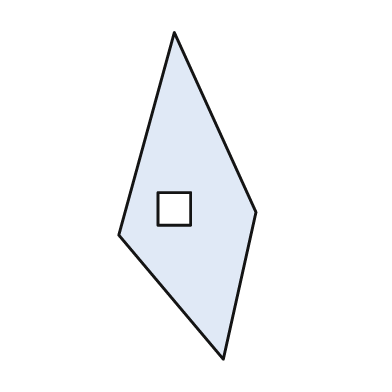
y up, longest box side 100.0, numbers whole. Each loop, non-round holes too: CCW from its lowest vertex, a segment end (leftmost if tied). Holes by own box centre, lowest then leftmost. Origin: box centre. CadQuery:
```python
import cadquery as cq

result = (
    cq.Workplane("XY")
    .moveTo(11.0, -50.0)
    .lineTo(21.0, -5.0)
    .lineTo(-4.0, 50.0)
    .lineTo(-21.0, -12.0)
    .close()
    .moveTo(-9.0, -9.0)
    .lineTo(1.0, -9.0)
    .lineTo(1.0, 1.0)
    .lineTo(-9.0, 1.0)
    .close()
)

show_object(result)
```